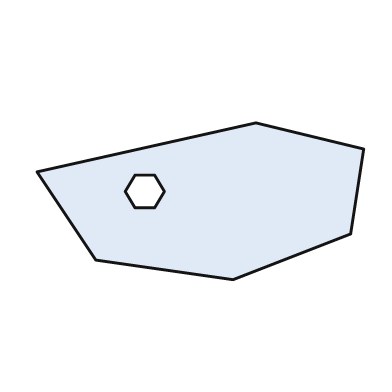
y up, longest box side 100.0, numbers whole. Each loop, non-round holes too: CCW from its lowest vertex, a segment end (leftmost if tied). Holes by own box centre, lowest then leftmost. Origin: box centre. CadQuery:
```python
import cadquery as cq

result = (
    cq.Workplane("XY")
    .moveTo(10.0, -24.0)
    .lineTo(46.0, -10.0)
    .lineTo(50.0, 16.0)
    .lineTo(17.0, 24.0)
    .lineTo(-50.0, 9.0)
    .lineTo(-32.0, -18.0)
    .close()
    .moveTo(-20.0, -2.0)
    .lineTo(-14.0, -2.0)
    .lineTo(-11.0, 3.0)
    .lineTo(-14.0, 8.0)
    .lineTo(-20.0, 8.0)
    .lineTo(-23.0, 3.0)
    .close()
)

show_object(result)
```